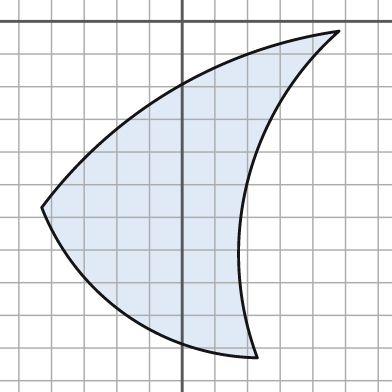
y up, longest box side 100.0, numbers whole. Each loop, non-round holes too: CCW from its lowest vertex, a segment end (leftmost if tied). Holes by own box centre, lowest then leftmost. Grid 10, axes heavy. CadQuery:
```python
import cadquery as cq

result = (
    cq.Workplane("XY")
    .moveTo(23.0, -103.0)
    .threePointArc((20.0, -49.0), (48.0, -3.0))
    .threePointArc((-3.0, -21.0), (-43.0, -57.0))
    .threePointArc((-17.0, -90.0), (23.0, -103.0))
    .close()
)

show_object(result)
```